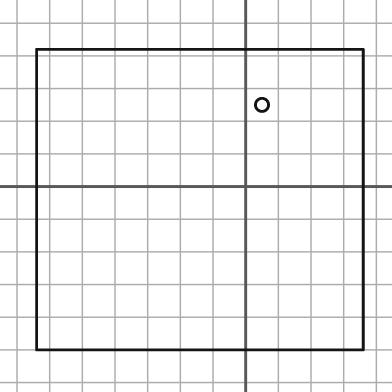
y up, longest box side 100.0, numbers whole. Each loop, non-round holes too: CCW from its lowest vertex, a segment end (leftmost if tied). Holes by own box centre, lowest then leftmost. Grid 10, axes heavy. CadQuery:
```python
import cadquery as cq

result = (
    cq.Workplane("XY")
    .moveTo(-64.0, -50.0)
    .lineTo(36.0, -50.0)
    .lineTo(36.0, 42.0)
    .lineTo(-64.0, 42.0)
    .close()
    .moveTo(5.0, 25.0)
    .circle(2.0)
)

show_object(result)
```